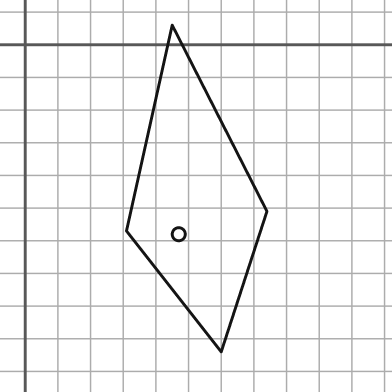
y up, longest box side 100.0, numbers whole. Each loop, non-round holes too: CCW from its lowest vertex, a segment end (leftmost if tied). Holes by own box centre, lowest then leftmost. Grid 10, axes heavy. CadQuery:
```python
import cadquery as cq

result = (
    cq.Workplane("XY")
    .moveTo(60.0, -94.0)
    .lineTo(74.0, -51.0)
    .lineTo(45.0, 6.0)
    .lineTo(31.0, -57.0)
    .close()
    .moveTo(47.0, -58.0)
    .circle(2.0)
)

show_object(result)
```